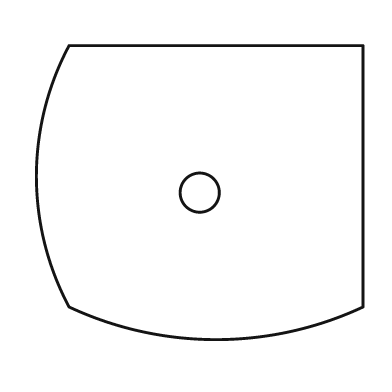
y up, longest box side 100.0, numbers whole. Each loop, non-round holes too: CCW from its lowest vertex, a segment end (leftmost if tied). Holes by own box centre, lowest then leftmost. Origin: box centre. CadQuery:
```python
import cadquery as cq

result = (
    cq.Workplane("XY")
    .moveTo(-40.0, -35.0)
    .threePointArc((5.0, -45.0), (50.0, -35.0))
    .lineTo(50.0, 45.0)
    .lineTo(-40.0, 45.0)
    .threePointArc((-50.0, 5.0), (-40.0, -35.0))
    .close()
    .moveTo(0.0, 0.0)
    .circle(6.0)
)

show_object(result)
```